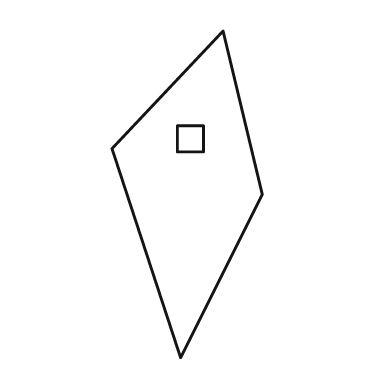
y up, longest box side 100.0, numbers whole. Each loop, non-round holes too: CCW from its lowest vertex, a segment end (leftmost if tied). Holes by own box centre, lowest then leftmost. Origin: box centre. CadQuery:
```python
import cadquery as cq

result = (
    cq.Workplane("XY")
    .moveTo(-2.0, -50.0)
    .lineTo(23.0, 0.0)
    .lineTo(11.0, 50.0)
    .lineTo(-23.0, 14.0)
    .close()
    .moveTo(-3.0, 13.0)
    .lineTo(5.0, 13.0)
    .lineTo(5.0, 21.0)
    .lineTo(-3.0, 21.0)
    .close()
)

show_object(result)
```